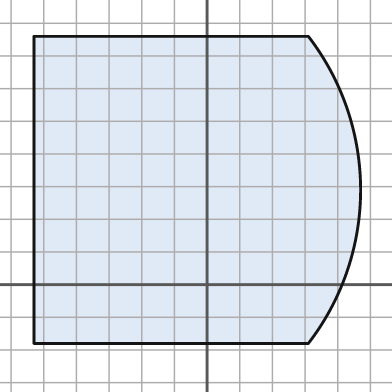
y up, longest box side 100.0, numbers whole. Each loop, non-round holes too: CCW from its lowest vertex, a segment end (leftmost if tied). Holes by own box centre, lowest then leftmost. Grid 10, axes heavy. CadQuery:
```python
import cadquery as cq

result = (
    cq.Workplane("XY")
    .moveTo(-53.0, -18.0)
    .lineTo(31.0, -18.0)
    .threePointArc((47.0, 29.0), (31.0, 76.0))
    .lineTo(-53.0, 76.0)
    .close()
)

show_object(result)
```